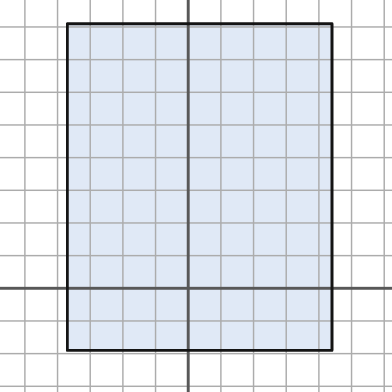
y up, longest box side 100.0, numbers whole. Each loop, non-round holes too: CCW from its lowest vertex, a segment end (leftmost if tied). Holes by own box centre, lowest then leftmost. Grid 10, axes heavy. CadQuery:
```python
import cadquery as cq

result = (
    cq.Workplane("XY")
    .moveTo(-37.0, -19.0)
    .lineTo(44.0, -19.0)
    .lineTo(44.0, 81.0)
    .lineTo(-37.0, 81.0)
    .close()
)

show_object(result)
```